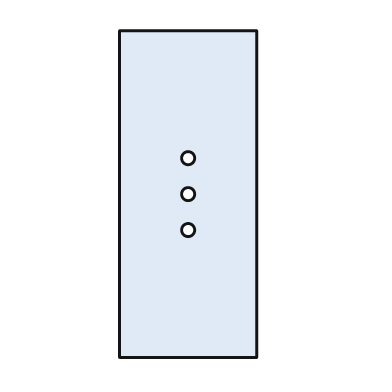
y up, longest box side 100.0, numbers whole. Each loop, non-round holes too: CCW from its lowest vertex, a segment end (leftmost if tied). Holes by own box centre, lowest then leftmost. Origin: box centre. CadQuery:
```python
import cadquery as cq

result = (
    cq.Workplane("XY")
    .moveTo(-21.0, -50.0)
    .lineTo(21.0, -50.0)
    .lineTo(21.0, 50.0)
    .lineTo(-21.0, 50.0)
    .close()
    .moveTo(0.0, -11.0)
    .circle(2.0)
    .moveTo(0.0, 0.0)
    .circle(2.0)
    .moveTo(0.0, 11.0)
    .circle(2.0)
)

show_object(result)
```